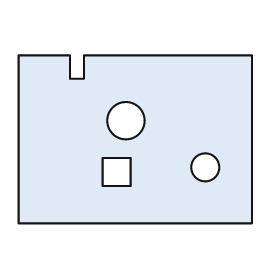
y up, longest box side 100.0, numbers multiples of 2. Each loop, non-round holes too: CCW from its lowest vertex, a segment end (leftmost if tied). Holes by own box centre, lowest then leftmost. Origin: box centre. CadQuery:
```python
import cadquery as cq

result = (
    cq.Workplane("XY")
    .moveTo(-50.0, -36.0)
    .lineTo(50.0, -36.0)
    .lineTo(50.0, 36.0)
    .lineTo(-22.0, 36.0)
    .lineTo(-22.0, 26.0)
    .lineTo(-28.0, 26.0)
    .lineTo(-28.0, 36.0)
    .lineTo(-50.0, 36.0)
    .close()
    .moveTo(-14.0, -20.0)
    .lineTo(-2.0, -20.0)
    .lineTo(-2.0, -8.0)
    .lineTo(-14.0, -8.0)
    .close()
    .moveTo(30.0, -12.0)
    .circle(6.0)
    .moveTo(-4.0, 8.0)
    .circle(8.0)
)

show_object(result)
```